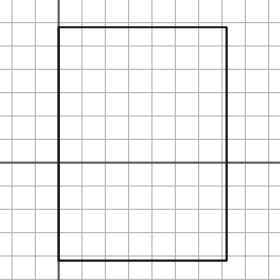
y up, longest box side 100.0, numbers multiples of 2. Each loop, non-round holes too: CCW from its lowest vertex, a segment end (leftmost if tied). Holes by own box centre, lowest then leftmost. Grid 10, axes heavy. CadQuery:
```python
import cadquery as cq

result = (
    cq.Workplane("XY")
    .moveTo(0.0, -42.0)
    .lineTo(72.0, -42.0)
    .lineTo(72.0, 58.0)
    .lineTo(0.0, 58.0)
    .close()
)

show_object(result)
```